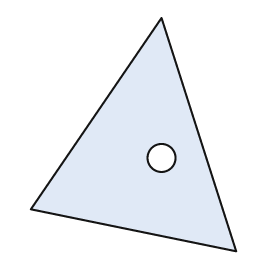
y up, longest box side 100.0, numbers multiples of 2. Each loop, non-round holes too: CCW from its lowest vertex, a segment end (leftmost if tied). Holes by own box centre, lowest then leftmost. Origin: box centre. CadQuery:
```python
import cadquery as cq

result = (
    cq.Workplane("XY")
    .moveTo(44.0, -50.0)
    .lineTo(12.0, 50.0)
    .lineTo(-44.0, -32.0)
    .close()
    .moveTo(12.0, -10.0)
    .circle(6.0)
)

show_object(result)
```